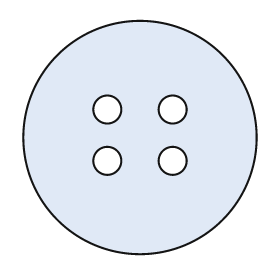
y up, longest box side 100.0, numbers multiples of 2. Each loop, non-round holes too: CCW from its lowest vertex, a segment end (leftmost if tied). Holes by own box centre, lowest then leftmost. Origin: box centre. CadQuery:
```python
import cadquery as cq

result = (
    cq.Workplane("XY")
    .moveTo(0.0, 0.0)
    .circle(50.0)
    .moveTo(-14.0, -10.0)
    .circle(6.0)
    .moveTo(14.0, -10.0)
    .circle(6.0)
    .moveTo(-14.0, 12.0)
    .circle(6.0)
    .moveTo(14.0, 12.0)
    .circle(6.0)
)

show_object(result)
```